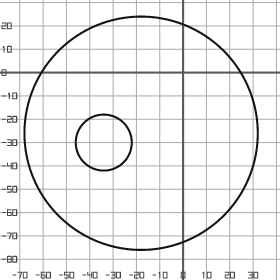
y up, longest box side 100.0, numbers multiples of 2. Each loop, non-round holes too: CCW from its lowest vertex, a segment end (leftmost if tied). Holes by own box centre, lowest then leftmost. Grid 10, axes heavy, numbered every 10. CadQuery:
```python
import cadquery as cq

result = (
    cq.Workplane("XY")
    .moveTo(-18.0, -26.0)
    .circle(50.0)
    .moveTo(-34.0, -30.0)
    .circle(12.0)
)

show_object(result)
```